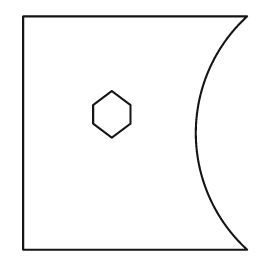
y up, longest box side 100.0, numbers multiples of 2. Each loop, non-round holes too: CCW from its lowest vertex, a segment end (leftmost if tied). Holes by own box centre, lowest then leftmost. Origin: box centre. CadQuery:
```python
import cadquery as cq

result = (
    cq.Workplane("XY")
    .moveTo(-48.0, -50.0)
    .lineTo(48.0, -50.0)
    .threePointArc((26.0, 0.0), (48.0, 50.0))
    .lineTo(-48.0, 50.0)
    .close()
    .moveTo(-10.0, -2.0)
    .lineTo(-2.0, 4.0)
    .lineTo(-2.0, 12.0)
    .lineTo(-10.0, 18.0)
    .lineTo(-18.0, 12.0)
    .lineTo(-18.0, 4.0)
    .close()
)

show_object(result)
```